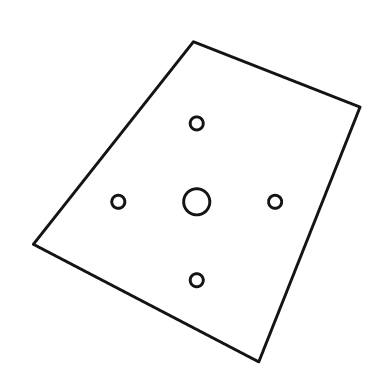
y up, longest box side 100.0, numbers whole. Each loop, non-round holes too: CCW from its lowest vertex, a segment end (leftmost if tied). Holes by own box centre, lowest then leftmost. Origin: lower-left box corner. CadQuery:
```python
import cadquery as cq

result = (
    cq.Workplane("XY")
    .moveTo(69.0, 0.0)
    .lineTo(100.0, 78.0)
    .lineTo(49.0, 98.0)
    .lineTo(0.0, 36.0)
    .close()
    .moveTo(50.0, 25.0)
    .circle(2.0)
    .moveTo(26.0, 49.0)
    .circle(2.0)
    .moveTo(50.0, 49.0)
    .circle(4.0)
    .moveTo(74.0, 49.0)
    .circle(2.0)
    .moveTo(50.0, 73.0)
    .circle(2.0)
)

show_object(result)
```